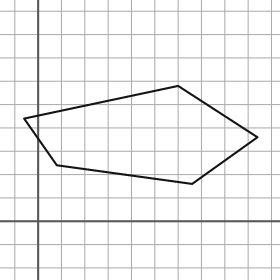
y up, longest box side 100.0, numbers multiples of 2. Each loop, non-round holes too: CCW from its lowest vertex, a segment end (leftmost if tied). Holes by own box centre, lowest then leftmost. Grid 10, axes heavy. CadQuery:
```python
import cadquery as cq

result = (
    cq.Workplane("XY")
    .moveTo(66.0, 16.0)
    .lineTo(94.0, 36.0)
    .lineTo(60.0, 58.0)
    .lineTo(-6.0, 44.0)
    .lineTo(8.0, 24.0)
    .close()
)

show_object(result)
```